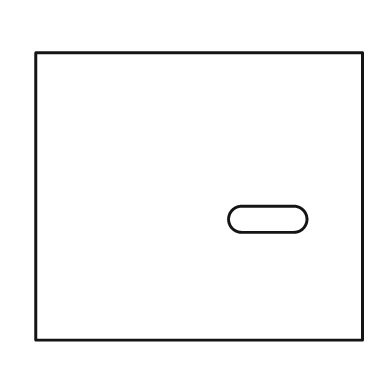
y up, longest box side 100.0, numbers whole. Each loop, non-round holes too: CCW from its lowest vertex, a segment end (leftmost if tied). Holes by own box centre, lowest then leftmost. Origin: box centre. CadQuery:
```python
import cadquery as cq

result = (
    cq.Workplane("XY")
    .moveTo(-50.0, -44.0)
    .lineTo(50.0, -44.0)
    .lineTo(50.0, 44.0)
    .lineTo(-50.0, 44.0)
    .close()
    .moveTo(13.0, -11.0)
    .lineTo(29.0, -11.0)
    .threePointArc((33.0, -7.0), (29.0, -3.0))
    .lineTo(13.0, -3.0)
    .threePointArc((9.0, -7.0), (13.0, -11.0))
    .close()
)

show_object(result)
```